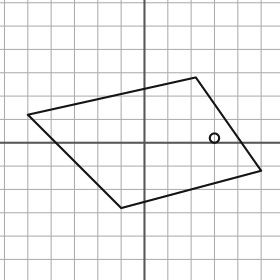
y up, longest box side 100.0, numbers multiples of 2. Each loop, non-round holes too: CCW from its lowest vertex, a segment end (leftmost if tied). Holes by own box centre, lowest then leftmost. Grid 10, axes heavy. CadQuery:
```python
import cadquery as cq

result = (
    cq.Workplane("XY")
    .moveTo(-10.0, -28.0)
    .lineTo(50.0, -12.0)
    .lineTo(22.0, 28.0)
    .lineTo(-50.0, 12.0)
    .close()
    .moveTo(30.0, 2.0)
    .circle(2.0)
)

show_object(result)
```